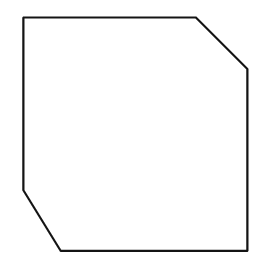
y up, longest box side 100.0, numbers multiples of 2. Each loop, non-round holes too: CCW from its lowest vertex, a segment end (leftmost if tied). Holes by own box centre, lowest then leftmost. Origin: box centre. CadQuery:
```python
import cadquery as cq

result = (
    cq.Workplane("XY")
    .moveTo(-32.0, -50.0)
    .lineTo(48.0, -50.0)
    .lineTo(48.0, 28.0)
    .lineTo(26.0, 50.0)
    .lineTo(-48.0, 50.0)
    .lineTo(-48.0, -24.0)
    .close()
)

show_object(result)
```